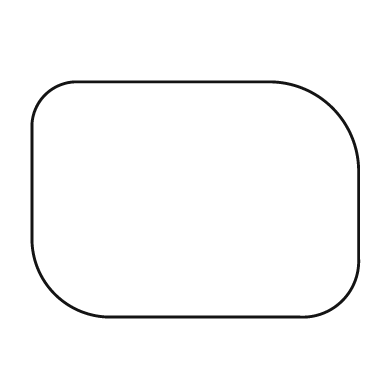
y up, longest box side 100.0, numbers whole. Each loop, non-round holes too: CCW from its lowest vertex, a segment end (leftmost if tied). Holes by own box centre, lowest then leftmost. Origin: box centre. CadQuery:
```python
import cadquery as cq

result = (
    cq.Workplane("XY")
    .moveTo(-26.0, -36.0)
    .lineTo(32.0, -36.0)
    .threePointArc((45.0, -31.0), (50.0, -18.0))
    .lineTo(50.0, 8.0)
    .threePointArc((42.0, 28.0), (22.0, 36.0))
    .lineTo(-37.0, 36.0)
    .threePointArc((-46.0, 32.0), (-50.0, 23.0))
    .lineTo(-50.0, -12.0)
    .threePointArc((-43.0, -29.0), (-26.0, -36.0))
    .close()
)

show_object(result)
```